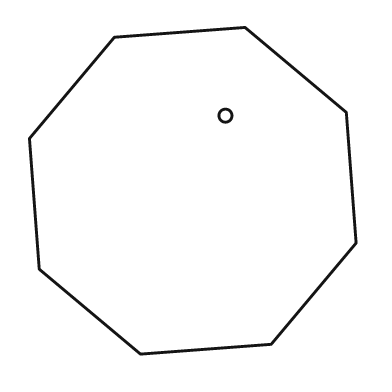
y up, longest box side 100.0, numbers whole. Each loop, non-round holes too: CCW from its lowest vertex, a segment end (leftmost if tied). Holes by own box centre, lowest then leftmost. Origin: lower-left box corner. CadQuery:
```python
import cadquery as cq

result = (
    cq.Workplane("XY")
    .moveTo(34.0, 0.0)
    .lineTo(74.0, 3.0)
    .lineTo(100.0, 34.0)
    .lineTo(97.0, 74.0)
    .lineTo(66.0, 100.0)
    .lineTo(26.0, 97.0)
    .lineTo(0.0, 66.0)
    .lineTo(3.0, 26.0)
    .close()
    .moveTo(60.0, 73.0)
    .circle(2.0)
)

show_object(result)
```